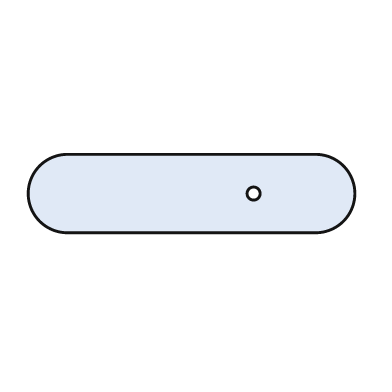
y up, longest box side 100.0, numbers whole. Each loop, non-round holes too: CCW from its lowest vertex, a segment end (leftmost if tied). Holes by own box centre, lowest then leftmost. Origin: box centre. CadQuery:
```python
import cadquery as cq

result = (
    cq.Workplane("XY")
    .moveTo(-38.0, -12.0)
    .lineTo(38.0, -12.0)
    .threePointArc((50.0, 0.0), (38.0, 12.0))
    .lineTo(-38.0, 12.0)
    .threePointArc((-50.0, 0.0), (-38.0, -12.0))
    .close()
    .moveTo(19.0, 0.0)
    .circle(2.0)
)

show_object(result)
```